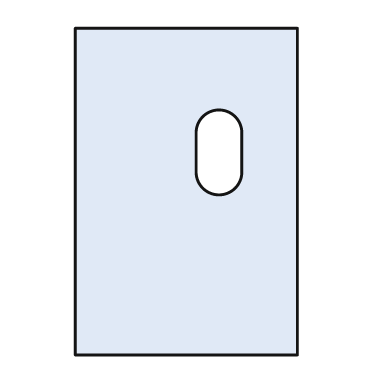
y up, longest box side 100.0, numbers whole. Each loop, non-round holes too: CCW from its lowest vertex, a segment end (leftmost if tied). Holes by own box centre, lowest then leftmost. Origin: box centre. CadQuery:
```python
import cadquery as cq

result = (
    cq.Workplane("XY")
    .moveTo(-34.0, -50.0)
    .lineTo(34.0, -50.0)
    .lineTo(34.0, 50.0)
    .lineTo(-34.0, 50.0)
    .close()
    .moveTo(3.0, 6.0)
    .threePointArc((10.0, -1.0), (17.0, 6.0))
    .lineTo(17.0, 18.0)
    .threePointArc((10.0, 25.0), (3.0, 18.0))
    .close()
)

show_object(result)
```